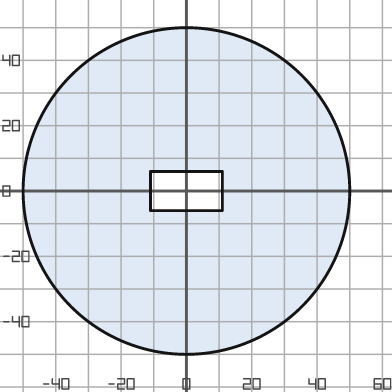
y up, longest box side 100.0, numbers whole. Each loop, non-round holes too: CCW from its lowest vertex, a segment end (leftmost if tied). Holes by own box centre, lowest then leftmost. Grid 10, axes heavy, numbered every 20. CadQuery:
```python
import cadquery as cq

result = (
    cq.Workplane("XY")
    .moveTo(0.0, 0.0)
    .circle(50.0)
    .moveTo(-11.0, -6.0)
    .lineTo(11.0, -6.0)
    .lineTo(11.0, 6.0)
    .lineTo(-11.0, 6.0)
    .close()
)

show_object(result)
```